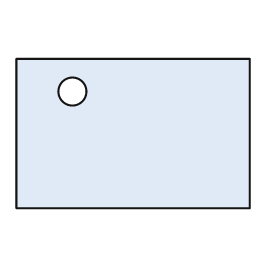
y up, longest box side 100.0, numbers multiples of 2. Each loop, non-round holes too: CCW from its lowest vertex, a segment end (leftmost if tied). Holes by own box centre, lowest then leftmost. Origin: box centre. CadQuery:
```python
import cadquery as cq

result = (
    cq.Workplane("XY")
    .moveTo(-50.0, -32.0)
    .lineTo(50.0, -32.0)
    .lineTo(50.0, 32.0)
    .lineTo(-50.0, 32.0)
    .close()
    .moveTo(-26.0, 18.0)
    .circle(6.0)
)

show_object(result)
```